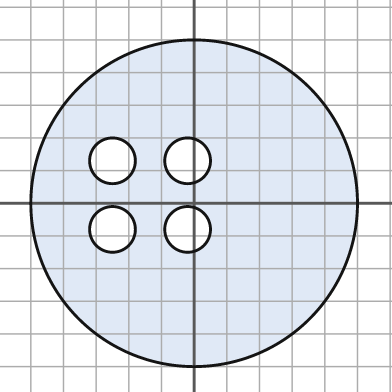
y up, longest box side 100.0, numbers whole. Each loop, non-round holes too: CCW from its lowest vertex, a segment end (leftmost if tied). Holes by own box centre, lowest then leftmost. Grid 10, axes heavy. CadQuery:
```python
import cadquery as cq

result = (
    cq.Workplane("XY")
    .moveTo(0.0, 0.0)
    .circle(50.0)
    .moveTo(-25.0, -8.0)
    .circle(7.0)
    .moveTo(-2.0, -8.0)
    .circle(7.0)
    .moveTo(-25.0, 13.0)
    .circle(7.0)
    .moveTo(-2.0, 13.0)
    .circle(7.0)
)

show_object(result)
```